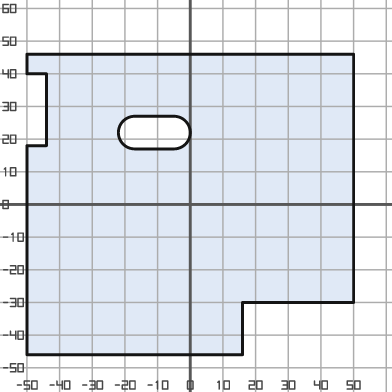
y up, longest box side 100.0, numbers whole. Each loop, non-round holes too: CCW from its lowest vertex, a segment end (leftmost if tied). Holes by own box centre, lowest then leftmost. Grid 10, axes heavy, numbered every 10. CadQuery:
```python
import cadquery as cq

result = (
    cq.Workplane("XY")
    .moveTo(-50.0, -46.0)
    .lineTo(16.0, -46.0)
    .lineTo(16.0, -30.0)
    .lineTo(50.0, -30.0)
    .lineTo(50.0, 46.0)
    .lineTo(-50.0, 46.0)
    .lineTo(-50.0, 40.0)
    .lineTo(-44.0, 40.0)
    .lineTo(-44.0, 18.0)
    .lineTo(-50.0, 18.0)
    .close()
    .moveTo(-17.0, 17.0)
    .lineTo(-5.0, 17.0)
    .threePointArc((0.0, 22.0), (-5.0, 27.0))
    .lineTo(-17.0, 27.0)
    .threePointArc((-22.0, 22.0), (-17.0, 17.0))
    .close()
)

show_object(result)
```